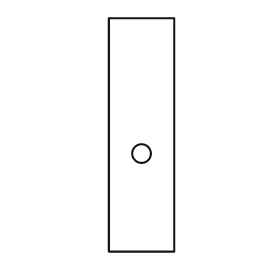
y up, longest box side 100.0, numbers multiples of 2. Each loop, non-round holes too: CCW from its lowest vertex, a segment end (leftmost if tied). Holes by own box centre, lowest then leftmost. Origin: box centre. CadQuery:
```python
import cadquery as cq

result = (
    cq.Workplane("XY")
    .moveTo(-14.0, -50.0)
    .lineTo(14.0, -50.0)
    .lineTo(14.0, 50.0)
    .lineTo(-14.0, 50.0)
    .close()
    .moveTo(0.0, -8.0)
    .circle(4.0)
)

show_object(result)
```